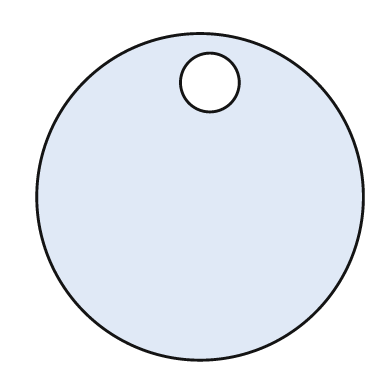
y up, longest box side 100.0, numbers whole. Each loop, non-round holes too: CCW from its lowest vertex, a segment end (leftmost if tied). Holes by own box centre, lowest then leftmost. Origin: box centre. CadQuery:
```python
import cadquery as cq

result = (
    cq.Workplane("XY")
    .moveTo(0.0, 0.0)
    .circle(50.0)
    .moveTo(3.0, 35.0)
    .circle(9.0)
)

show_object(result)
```